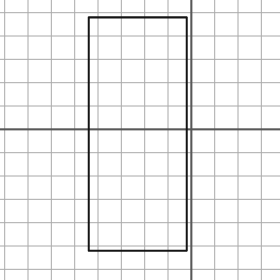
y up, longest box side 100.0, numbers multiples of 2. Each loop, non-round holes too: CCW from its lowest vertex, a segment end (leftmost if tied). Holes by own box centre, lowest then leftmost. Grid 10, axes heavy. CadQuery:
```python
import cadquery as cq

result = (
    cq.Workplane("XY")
    .moveTo(-44.0, -52.0)
    .lineTo(-2.0, -52.0)
    .lineTo(-2.0, 48.0)
    .lineTo(-44.0, 48.0)
    .close()
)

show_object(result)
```